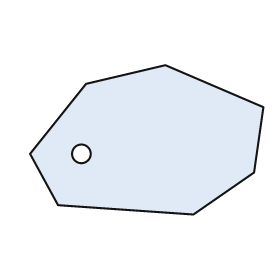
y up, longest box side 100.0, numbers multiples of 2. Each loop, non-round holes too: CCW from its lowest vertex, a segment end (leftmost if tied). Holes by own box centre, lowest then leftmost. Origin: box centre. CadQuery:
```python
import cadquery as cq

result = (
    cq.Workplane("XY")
    .moveTo(20.0, -32.0)
    .lineTo(46.0, -14.0)
    .lineTo(50.0, 14.0)
    .lineTo(8.0, 32.0)
    .lineTo(-26.0, 24.0)
    .lineTo(-50.0, -6.0)
    .lineTo(-38.0, -28.0)
    .close()
    .moveTo(-28.0, -6.0)
    .circle(4.0)
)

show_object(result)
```